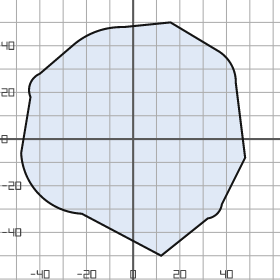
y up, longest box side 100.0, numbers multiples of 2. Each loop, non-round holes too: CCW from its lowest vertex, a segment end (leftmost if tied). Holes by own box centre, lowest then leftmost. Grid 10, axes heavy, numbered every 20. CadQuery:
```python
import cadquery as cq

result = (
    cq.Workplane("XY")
    .moveTo(12.0, -50.0)
    .lineTo(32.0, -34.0)
    .threePointArc((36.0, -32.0), (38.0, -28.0))
    .lineTo(48.0, -8.0)
    .lineTo(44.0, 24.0)
    .threePointArc((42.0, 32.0), (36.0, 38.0))
    .lineTo(16.0, 50.0)
    .lineTo(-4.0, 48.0)
    .threePointArc((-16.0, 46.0), (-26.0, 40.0))
    .lineTo(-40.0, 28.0)
    .threePointArc((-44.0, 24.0), (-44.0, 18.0))
    .lineTo(-48.0, -6.0)
    .threePointArc((-40.0, -24.0), (-22.0, -32.0))
    .close()
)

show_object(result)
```